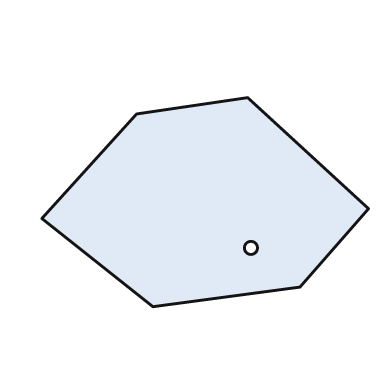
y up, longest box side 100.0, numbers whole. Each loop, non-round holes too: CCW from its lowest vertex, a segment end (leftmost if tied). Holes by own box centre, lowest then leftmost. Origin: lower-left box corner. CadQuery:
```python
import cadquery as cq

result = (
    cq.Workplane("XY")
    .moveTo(34.0, 0.0)
    .lineTo(79.0, 6.0)
    .lineTo(100.0, 30.0)
    .lineTo(63.0, 64.0)
    .lineTo(29.0, 59.0)
    .lineTo(0.0, 27.0)
    .close()
    .moveTo(64.0, 18.0)
    .circle(2.0)
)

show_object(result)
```